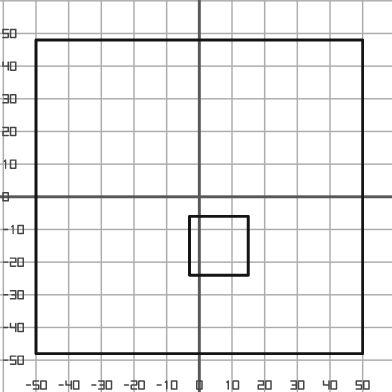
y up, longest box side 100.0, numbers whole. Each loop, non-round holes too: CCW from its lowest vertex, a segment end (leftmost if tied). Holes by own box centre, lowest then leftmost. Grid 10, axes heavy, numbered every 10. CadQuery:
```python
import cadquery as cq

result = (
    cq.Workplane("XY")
    .moveTo(-50.0, -48.0)
    .lineTo(50.0, -48.0)
    .lineTo(50.0, 48.0)
    .lineTo(-50.0, 48.0)
    .close()
    .moveTo(-3.0, -24.0)
    .lineTo(15.0, -24.0)
    .lineTo(15.0, -6.0)
    .lineTo(-3.0, -6.0)
    .close()
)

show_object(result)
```